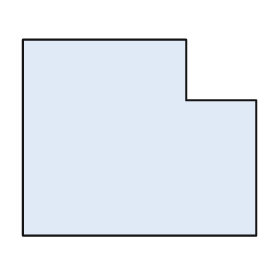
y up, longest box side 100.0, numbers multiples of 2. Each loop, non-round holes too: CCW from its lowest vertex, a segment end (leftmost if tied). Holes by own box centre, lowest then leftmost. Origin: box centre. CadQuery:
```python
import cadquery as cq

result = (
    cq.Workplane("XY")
    .moveTo(-50.0, -42.0)
    .lineTo(50.0, -42.0)
    .lineTo(50.0, 16.0)
    .lineTo(20.0, 16.0)
    .lineTo(20.0, 42.0)
    .lineTo(-50.0, 42.0)
    .close()
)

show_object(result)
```